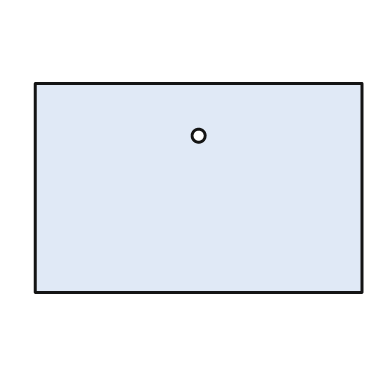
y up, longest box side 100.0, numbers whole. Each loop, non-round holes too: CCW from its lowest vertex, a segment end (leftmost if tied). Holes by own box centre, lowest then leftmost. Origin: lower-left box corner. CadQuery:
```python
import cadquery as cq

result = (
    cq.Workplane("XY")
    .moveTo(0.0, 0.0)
    .lineTo(100.0, 0.0)
    .lineTo(100.0, 64.0)
    .lineTo(0.0, 64.0)
    .close()
    .moveTo(50.0, 48.0)
    .circle(2.0)
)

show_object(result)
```